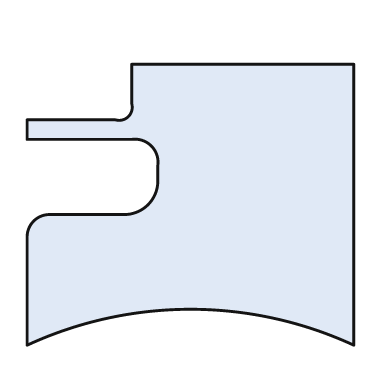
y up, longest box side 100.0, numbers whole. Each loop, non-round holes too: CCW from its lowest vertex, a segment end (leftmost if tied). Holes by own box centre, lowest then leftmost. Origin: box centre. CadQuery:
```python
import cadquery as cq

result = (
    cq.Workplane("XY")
    .moveTo(-50.0, -43.0)
    .threePointArc((0.0, -32.0), (50.0, -43.0))
    .lineTo(50.0, 43.0)
    .lineTo(-18.0, 43.0)
    .lineTo(-18.0, 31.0)
    .threePointArc((-19.0, 27.0), (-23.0, 26.0))
    .lineTo(-50.0, 26.0)
    .lineTo(-50.0, 20.0)
    .lineTo(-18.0, 20.0)
    .threePointArc((-12.0, 18.0), (-10.0, 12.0))
    .lineTo(-10.0, 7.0)
    .threePointArc((-13.0, 0.0), (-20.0, -3.0))
    .lineTo(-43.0, -3.0)
    .threePointArc((-48.0, -5.0), (-50.0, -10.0))
    .close()
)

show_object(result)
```